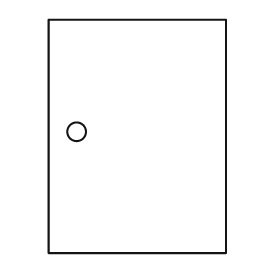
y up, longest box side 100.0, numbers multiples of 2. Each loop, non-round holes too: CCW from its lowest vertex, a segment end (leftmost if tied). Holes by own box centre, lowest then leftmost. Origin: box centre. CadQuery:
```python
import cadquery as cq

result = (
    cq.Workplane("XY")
    .moveTo(-38.0, -50.0)
    .lineTo(38.0, -50.0)
    .lineTo(38.0, 50.0)
    .lineTo(-38.0, 50.0)
    .close()
    .moveTo(-26.0, 2.0)
    .circle(4.0)
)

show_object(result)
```